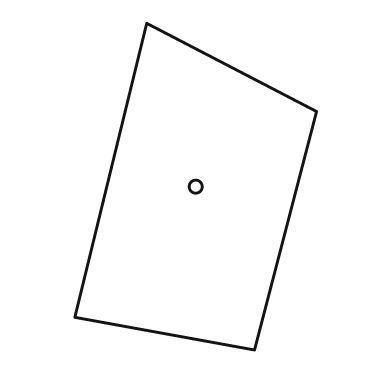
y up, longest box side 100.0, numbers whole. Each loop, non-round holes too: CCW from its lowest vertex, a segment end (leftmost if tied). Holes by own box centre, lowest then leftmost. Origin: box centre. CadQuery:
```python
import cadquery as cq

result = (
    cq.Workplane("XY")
    .moveTo(18.0, -50.0)
    .lineTo(37.0, 23.0)
    .lineTo(-15.0, 50.0)
    .lineTo(-37.0, -40.0)
    .close()
    .moveTo(0.0, 0.0)
    .circle(2.0)
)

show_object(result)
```